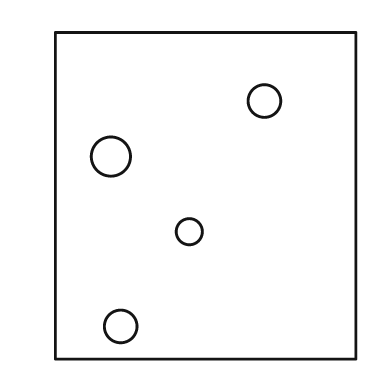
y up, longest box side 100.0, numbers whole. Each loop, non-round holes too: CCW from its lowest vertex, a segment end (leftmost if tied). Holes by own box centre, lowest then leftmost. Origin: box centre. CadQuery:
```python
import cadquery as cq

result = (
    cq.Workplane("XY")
    .moveTo(-46.0, -50.0)
    .lineTo(46.0, -50.0)
    .lineTo(46.0, 50.0)
    .lineTo(-46.0, 50.0)
    .close()
    .moveTo(-26.0, -40.0)
    .circle(5.0)
    .moveTo(-5.0, -11.0)
    .circle(4.0)
    .moveTo(-29.0, 12.0)
    .circle(6.0)
    .moveTo(18.0, 29.0)
    .circle(5.0)
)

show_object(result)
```